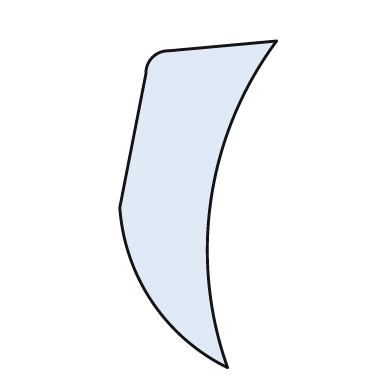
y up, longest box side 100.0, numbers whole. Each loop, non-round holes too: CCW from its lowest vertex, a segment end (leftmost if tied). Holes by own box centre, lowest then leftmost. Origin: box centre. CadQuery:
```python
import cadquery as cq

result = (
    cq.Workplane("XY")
    .moveTo(9.0, -50.0)
    .threePointArc((4.0, 2.0), (24.0, 50.0))
    .lineTo(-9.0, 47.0)
    .threePointArc((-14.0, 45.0), (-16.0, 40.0))
    .lineTo(-24.0, -1.0)
    .threePointArc((-14.0, -30.0), (9.0, -50.0))
    .close()
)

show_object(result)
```